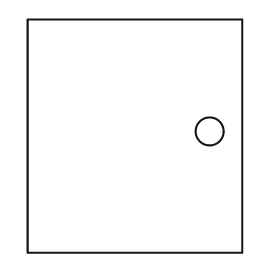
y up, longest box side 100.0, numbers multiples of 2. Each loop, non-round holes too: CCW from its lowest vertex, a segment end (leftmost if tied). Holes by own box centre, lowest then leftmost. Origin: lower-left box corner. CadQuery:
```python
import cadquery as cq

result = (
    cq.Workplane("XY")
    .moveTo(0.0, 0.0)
    .lineTo(92.0, 0.0)
    .lineTo(92.0, 100.0)
    .lineTo(0.0, 100.0)
    .close()
    .moveTo(78.0, 52.0)
    .circle(6.0)
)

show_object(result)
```